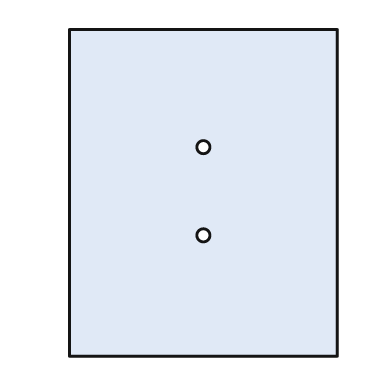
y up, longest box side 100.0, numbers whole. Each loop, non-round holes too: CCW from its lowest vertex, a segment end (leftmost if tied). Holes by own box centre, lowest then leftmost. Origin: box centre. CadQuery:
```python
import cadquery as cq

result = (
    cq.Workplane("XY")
    .moveTo(-41.0, -50.0)
    .lineTo(41.0, -50.0)
    .lineTo(41.0, 50.0)
    .lineTo(-41.0, 50.0)
    .close()
    .moveTo(0.0, -13.0)
    .circle(2.0)
    .moveTo(0.0, 14.0)
    .circle(2.0)
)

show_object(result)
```